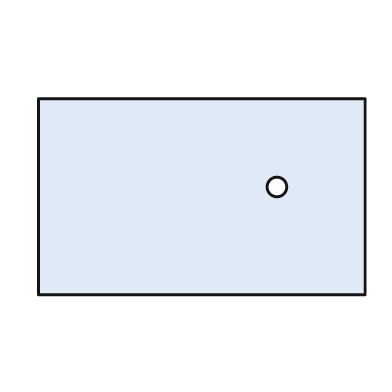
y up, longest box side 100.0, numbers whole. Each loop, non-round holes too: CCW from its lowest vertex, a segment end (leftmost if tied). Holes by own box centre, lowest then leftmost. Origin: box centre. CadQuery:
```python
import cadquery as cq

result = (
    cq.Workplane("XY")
    .moveTo(-50.0, -30.0)
    .lineTo(50.0, -30.0)
    .lineTo(50.0, 30.0)
    .lineTo(-50.0, 30.0)
    .close()
    .moveTo(23.0, 3.0)
    .circle(3.0)
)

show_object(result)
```